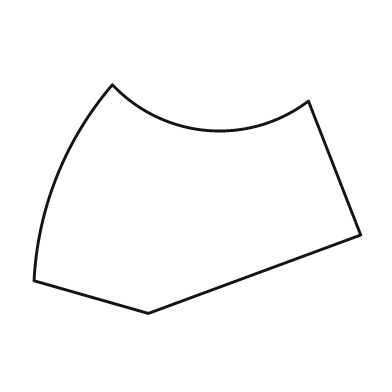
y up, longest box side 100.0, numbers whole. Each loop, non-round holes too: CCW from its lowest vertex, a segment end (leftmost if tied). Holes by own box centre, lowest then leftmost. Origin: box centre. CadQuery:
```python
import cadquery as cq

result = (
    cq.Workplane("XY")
    .moveTo(-15.0, -35.0)
    .lineTo(50.0, -11.0)
    .lineTo(34.0, 30.0)
    .threePointArc((3.0, 21.0), (-26.0, 35.0))
    .threePointArc((-43.0, 7.0), (-50.0, -25.0))
    .close()
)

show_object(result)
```